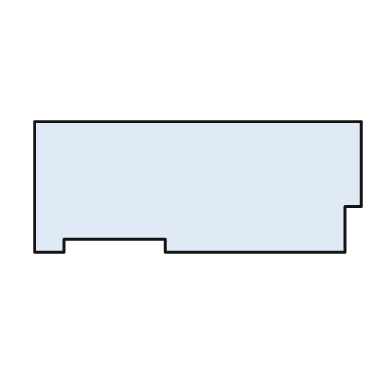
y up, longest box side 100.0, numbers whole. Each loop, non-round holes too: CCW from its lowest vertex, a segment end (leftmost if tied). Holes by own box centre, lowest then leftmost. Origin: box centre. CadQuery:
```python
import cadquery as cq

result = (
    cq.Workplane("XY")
    .moveTo(-50.0, -20.0)
    .lineTo(-41.0, -20.0)
    .lineTo(-41.0, -16.0)
    .lineTo(-10.0, -16.0)
    .lineTo(-10.0, -20.0)
    .lineTo(45.0, -20.0)
    .lineTo(45.0, -6.0)
    .lineTo(50.0, -6.0)
    .lineTo(50.0, 20.0)
    .lineTo(-50.0, 20.0)
    .close()
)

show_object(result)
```